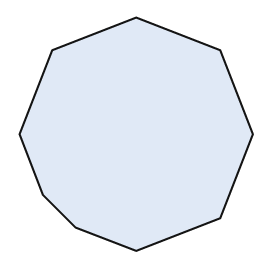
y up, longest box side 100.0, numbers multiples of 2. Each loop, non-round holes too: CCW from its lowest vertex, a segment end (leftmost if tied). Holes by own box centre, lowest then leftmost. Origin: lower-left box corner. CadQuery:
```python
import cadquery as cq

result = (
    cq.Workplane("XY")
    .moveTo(50.0, 0.0)
    .lineTo(86.0, 14.0)
    .lineTo(100.0, 50.0)
    .lineTo(86.0, 86.0)
    .lineTo(50.0, 100.0)
    .lineTo(14.0, 86.0)
    .lineTo(0.0, 50.0)
    .lineTo(10.0, 24.0)
    .lineTo(24.0, 10.0)
    .close()
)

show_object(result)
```